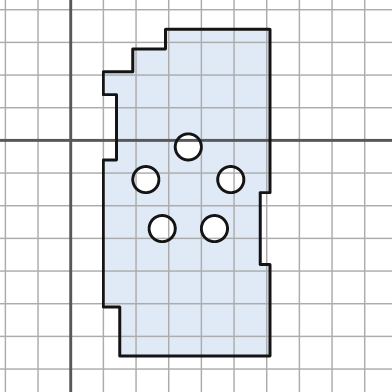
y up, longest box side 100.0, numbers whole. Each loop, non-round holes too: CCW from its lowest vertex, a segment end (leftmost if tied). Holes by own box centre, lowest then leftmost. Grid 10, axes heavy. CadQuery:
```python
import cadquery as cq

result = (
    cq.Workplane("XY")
    .moveTo(15.0, -66.0)
    .lineTo(61.0, -66.0)
    .lineTo(61.0, -38.0)
    .lineTo(58.0, -38.0)
    .lineTo(58.0, -16.0)
    .lineTo(61.0, -16.0)
    .lineTo(61.0, 34.0)
    .lineTo(29.0, 34.0)
    .lineTo(29.0, 28.0)
    .lineTo(19.0, 28.0)
    .lineTo(19.0, 21.0)
    .lineTo(10.0, 21.0)
    .lineTo(10.0, 14.0)
    .lineTo(14.0, 14.0)
    .lineTo(14.0, -6.0)
    .lineTo(10.0, -6.0)
    .lineTo(10.0, -51.0)
    .lineTo(15.0, -51.0)
    .close()
    .moveTo(28.0, -27.0)
    .circle(4.0)
    .moveTo(44.0, -27.0)
    .circle(4.0)
    .moveTo(23.0, -12.0)
    .circle(4.0)
    .moveTo(49.0, -12.0)
    .circle(4.0)
    .moveTo(36.0, -2.0)
    .circle(4.0)
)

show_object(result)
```